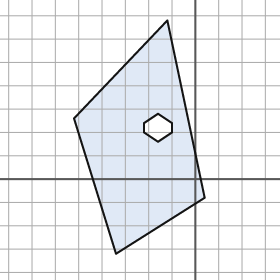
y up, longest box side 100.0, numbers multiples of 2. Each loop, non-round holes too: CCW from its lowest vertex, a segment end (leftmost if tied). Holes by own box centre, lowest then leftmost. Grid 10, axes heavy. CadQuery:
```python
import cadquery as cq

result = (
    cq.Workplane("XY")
    .moveTo(-34.0, -32.0)
    .lineTo(4.0, -8.0)
    .lineTo(-12.0, 68.0)
    .lineTo(-52.0, 26.0)
    .close()
    .moveTo(-16.0, 16.0)
    .lineTo(-10.0, 20.0)
    .lineTo(-10.0, 24.0)
    .lineTo(-16.0, 28.0)
    .lineTo(-22.0, 24.0)
    .lineTo(-22.0, 20.0)
    .close()
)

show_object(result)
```